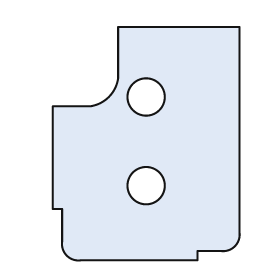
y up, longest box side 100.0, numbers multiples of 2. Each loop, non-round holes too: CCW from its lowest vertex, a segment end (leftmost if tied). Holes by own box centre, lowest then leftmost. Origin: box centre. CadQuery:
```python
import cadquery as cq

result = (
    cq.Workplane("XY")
    .moveTo(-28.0, -50.0)
    .lineTo(22.0, -50.0)
    .lineTo(22.0, -46.0)
    .lineTo(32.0, -46.0)
    .threePointArc((38.0, -44.0), (40.0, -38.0))
    .lineTo(40.0, 50.0)
    .lineTo(-12.0, 50.0)
    .lineTo(-12.0, 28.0)
    .threePointArc((-16.0, 20.0), (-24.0, 16.0))
    .lineTo(-40.0, 16.0)
    .lineTo(-40.0, -28.0)
    .lineTo(-36.0, -28.0)
    .lineTo(-36.0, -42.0)
    .threePointArc((-34.0, -48.0), (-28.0, -50.0))
    .close()
    .moveTo(0.0, -18.0)
    .circle(8.0)
    .moveTo(0.0, 20.0)
    .circle(8.0)
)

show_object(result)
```